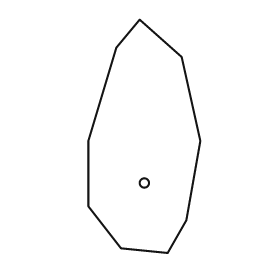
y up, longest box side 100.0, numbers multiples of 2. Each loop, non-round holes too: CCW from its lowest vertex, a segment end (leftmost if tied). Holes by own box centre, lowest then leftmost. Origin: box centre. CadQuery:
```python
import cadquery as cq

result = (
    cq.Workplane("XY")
    .moveTo(10.0, -50.0)
    .lineTo(18.0, -36.0)
    .lineTo(24.0, -2.0)
    .lineTo(16.0, 34.0)
    .lineTo(-2.0, 50.0)
    .lineTo(-12.0, 38.0)
    .lineTo(-24.0, -2.0)
    .lineTo(-24.0, -30.0)
    .lineTo(-10.0, -48.0)
    .close()
    .moveTo(0.0, -20.0)
    .circle(2.0)
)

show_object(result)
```